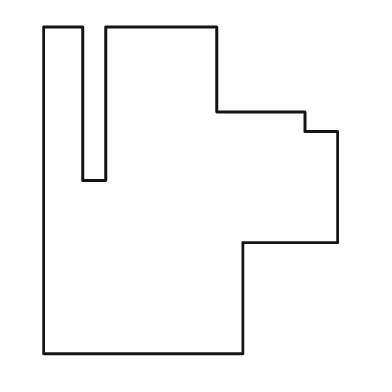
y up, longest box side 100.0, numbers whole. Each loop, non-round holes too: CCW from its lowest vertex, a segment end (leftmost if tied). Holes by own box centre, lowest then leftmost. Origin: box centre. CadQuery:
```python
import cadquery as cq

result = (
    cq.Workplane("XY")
    .moveTo(-45.0, -50.0)
    .lineTo(16.0, -50.0)
    .lineTo(16.0, -16.0)
    .lineTo(45.0, -16.0)
    .lineTo(45.0, 18.0)
    .lineTo(35.0, 18.0)
    .lineTo(35.0, 24.0)
    .lineTo(8.0, 24.0)
    .lineTo(8.0, 50.0)
    .lineTo(-26.0, 50.0)
    .lineTo(-26.0, 3.0)
    .lineTo(-33.0, 3.0)
    .lineTo(-33.0, 50.0)
    .lineTo(-45.0, 50.0)
    .close()
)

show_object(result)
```